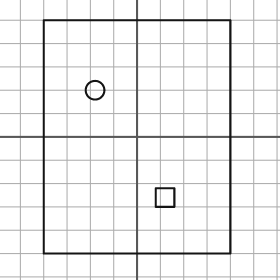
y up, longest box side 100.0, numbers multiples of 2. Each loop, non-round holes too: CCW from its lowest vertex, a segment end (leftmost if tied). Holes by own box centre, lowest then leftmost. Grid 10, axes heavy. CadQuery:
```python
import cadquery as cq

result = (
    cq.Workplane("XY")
    .moveTo(-40.0, -50.0)
    .lineTo(40.0, -50.0)
    .lineTo(40.0, 50.0)
    .lineTo(-40.0, 50.0)
    .close()
    .moveTo(8.0, -30.0)
    .lineTo(16.0, -30.0)
    .lineTo(16.0, -22.0)
    .lineTo(8.0, -22.0)
    .close()
    .moveTo(-18.0, 20.0)
    .circle(4.0)
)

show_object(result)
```